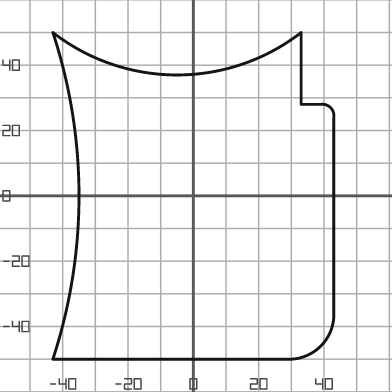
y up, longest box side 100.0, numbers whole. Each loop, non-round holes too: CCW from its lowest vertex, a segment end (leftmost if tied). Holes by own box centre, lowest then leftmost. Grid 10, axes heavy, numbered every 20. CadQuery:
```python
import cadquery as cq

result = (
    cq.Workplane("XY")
    .moveTo(-43.0, -50.0)
    .lineTo(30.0, -50.0)
    .threePointArc((39.0, -46.0), (43.0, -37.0))
    .lineTo(43.0, 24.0)
    .threePointArc((42.0, 27.0), (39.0, 28.0))
    .lineTo(33.0, 28.0)
    .lineTo(33.0, 50.0)
    .threePointArc((-5.0, 37.0), (-43.0, 50.0))
    .threePointArc((-35.0, 0.0), (-43.0, -50.0))
    .close()
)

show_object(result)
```